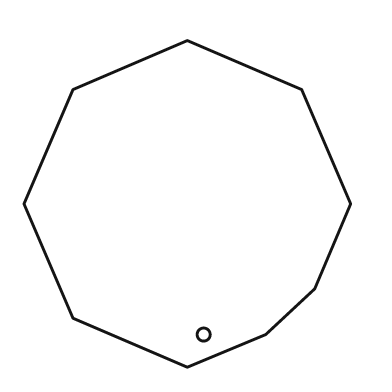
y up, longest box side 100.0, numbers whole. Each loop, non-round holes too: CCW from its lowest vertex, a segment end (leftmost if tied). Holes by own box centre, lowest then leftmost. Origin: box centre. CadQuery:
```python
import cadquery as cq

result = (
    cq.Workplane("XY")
    .moveTo(0.0, -50.0)
    .lineTo(24.0, -40.0)
    .lineTo(39.0, -26.0)
    .lineTo(50.0, 0.0)
    .lineTo(35.0, 35.0)
    .lineTo(0.0, 50.0)
    .lineTo(-35.0, 35.0)
    .lineTo(-50.0, 0.0)
    .lineTo(-35.0, -35.0)
    .close()
    .moveTo(5.0, -40.0)
    .circle(2.0)
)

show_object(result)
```